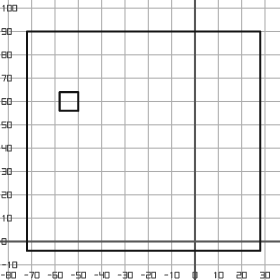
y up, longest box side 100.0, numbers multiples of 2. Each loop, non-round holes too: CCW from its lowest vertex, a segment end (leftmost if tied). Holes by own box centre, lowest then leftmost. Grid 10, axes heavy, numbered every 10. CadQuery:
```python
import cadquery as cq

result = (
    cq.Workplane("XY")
    .moveTo(-72.0, -4.0)
    .lineTo(28.0, -4.0)
    .lineTo(28.0, 90.0)
    .lineTo(-72.0, 90.0)
    .close()
    .moveTo(-58.0, 56.0)
    .lineTo(-50.0, 56.0)
    .lineTo(-50.0, 64.0)
    .lineTo(-58.0, 64.0)
    .close()
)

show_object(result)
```